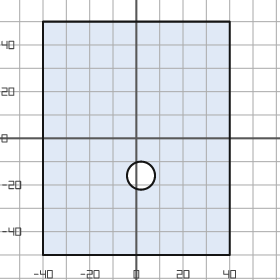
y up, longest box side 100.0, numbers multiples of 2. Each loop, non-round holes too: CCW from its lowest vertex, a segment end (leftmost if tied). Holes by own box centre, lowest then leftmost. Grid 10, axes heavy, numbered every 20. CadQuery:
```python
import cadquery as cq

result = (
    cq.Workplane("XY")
    .moveTo(-40.0, -50.0)
    .lineTo(40.0, -50.0)
    .lineTo(40.0, 50.0)
    .lineTo(-40.0, 50.0)
    .close()
    .moveTo(2.0, -16.0)
    .circle(6.0)
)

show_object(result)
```